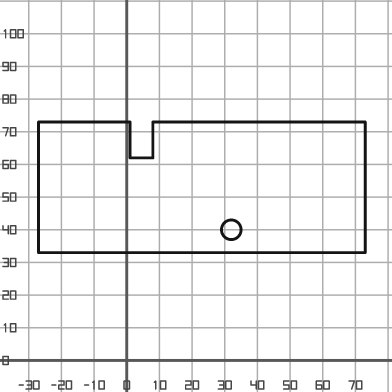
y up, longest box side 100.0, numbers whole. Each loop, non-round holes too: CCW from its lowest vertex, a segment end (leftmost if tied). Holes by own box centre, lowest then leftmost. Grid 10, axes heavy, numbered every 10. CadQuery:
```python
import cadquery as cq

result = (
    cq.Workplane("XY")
    .moveTo(-27.0, 33.0)
    .lineTo(73.0, 33.0)
    .lineTo(73.0, 73.0)
    .lineTo(8.0, 73.0)
    .lineTo(8.0, 62.0)
    .lineTo(1.0, 62.0)
    .lineTo(1.0, 73.0)
    .lineTo(-27.0, 73.0)
    .close()
    .moveTo(32.0, 40.0)
    .circle(3.0)
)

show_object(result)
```